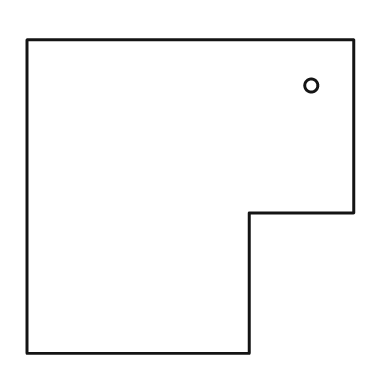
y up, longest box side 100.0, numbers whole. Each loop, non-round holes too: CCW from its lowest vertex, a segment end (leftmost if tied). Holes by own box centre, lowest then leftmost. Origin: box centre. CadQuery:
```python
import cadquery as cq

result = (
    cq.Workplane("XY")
    .moveTo(-50.0, -48.0)
    .lineTo(18.0, -48.0)
    .lineTo(18.0, -5.0)
    .lineTo(50.0, -5.0)
    .lineTo(50.0, 48.0)
    .lineTo(-50.0, 48.0)
    .close()
    .moveTo(37.0, 34.0)
    .circle(2.0)
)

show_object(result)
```